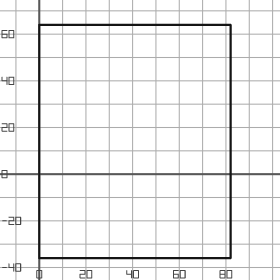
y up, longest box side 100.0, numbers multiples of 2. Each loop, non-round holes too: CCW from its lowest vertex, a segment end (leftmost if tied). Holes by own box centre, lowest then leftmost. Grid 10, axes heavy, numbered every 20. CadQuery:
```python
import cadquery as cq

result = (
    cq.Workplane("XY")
    .moveTo(0.0, -36.0)
    .lineTo(82.0, -36.0)
    .lineTo(82.0, 64.0)
    .lineTo(0.0, 64.0)
    .close()
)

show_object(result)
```